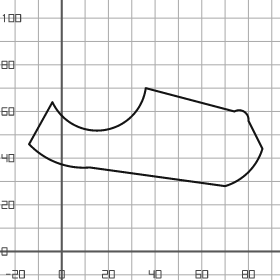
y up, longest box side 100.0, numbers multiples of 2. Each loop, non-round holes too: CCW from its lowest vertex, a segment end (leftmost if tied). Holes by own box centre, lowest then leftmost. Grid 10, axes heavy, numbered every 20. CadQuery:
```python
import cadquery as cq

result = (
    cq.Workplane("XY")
    .moveTo(70.0, 28.0)
    .threePointArc((80.0, 34.0), (86.0, 44.0))
    .lineTo(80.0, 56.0)
    .threePointArc((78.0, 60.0), (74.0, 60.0))
    .lineTo(36.0, 70.0)
    .threePointArc((18.0, 52.0), (-4.0, 64.0))
    .lineTo(-14.0, 46.0)
    .threePointArc((-2.0, 38.0), (12.0, 36.0))
    .close()
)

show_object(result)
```